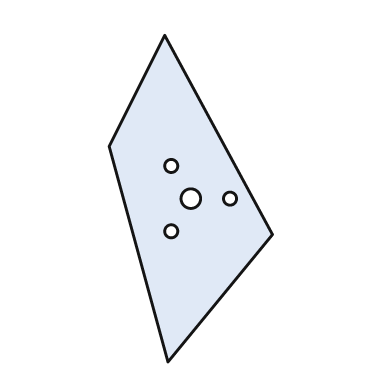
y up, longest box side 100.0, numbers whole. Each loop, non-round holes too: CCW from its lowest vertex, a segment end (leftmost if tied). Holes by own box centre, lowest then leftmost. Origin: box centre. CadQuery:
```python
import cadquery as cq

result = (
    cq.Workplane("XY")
    .moveTo(-7.0, -50.0)
    .lineTo(25.0, -11.0)
    .lineTo(-8.0, 50.0)
    .lineTo(-25.0, 16.0)
    .close()
    .moveTo(-6.0, -10.0)
    .circle(2.0)
    .moveTo(0.0, 0.0)
    .circle(3.0)
    .moveTo(12.0, 0.0)
    .circle(2.0)
    .moveTo(-6.0, 10.0)
    .circle(2.0)
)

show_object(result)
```